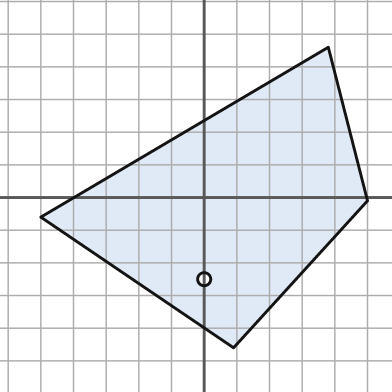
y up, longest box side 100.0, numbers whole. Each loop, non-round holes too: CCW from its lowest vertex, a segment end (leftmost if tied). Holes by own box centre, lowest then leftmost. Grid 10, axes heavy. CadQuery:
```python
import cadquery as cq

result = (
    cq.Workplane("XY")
    .moveTo(9.0, -46.0)
    .lineTo(50.0, -1.0)
    .lineTo(38.0, 46.0)
    .lineTo(-50.0, -6.0)
    .close()
    .moveTo(0.0, -25.0)
    .circle(2.0)
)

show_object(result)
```